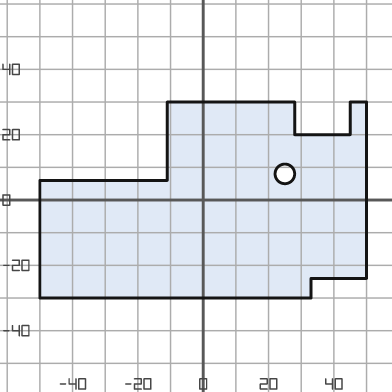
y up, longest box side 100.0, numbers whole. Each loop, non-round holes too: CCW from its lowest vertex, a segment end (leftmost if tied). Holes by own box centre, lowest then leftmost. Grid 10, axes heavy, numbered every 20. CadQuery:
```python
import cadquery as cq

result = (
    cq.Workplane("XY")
    .moveTo(-50.0, -30.0)
    .lineTo(33.0, -30.0)
    .lineTo(33.0, -24.0)
    .lineTo(50.0, -24.0)
    .lineTo(50.0, 30.0)
    .lineTo(45.0, 30.0)
    .lineTo(45.0, 20.0)
    .lineTo(28.0, 20.0)
    .lineTo(28.0, 30.0)
    .lineTo(-11.0, 30.0)
    .lineTo(-11.0, 6.0)
    .lineTo(-50.0, 6.0)
    .close()
    .moveTo(25.0, 8.0)
    .circle(3.0)
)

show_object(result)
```